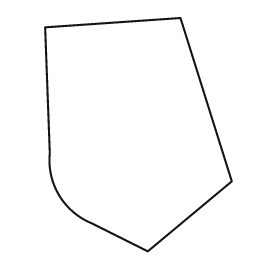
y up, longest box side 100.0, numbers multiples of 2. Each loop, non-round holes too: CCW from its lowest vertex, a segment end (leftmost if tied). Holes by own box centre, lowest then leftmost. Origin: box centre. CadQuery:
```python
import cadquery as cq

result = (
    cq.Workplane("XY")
    .moveTo(4.0, -50.0)
    .lineTo(40.0, -20.0)
    .lineTo(18.0, 50.0)
    .lineTo(-40.0, 46.0)
    .lineTo(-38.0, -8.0)
    .threePointArc((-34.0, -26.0), (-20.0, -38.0))
    .close()
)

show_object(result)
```